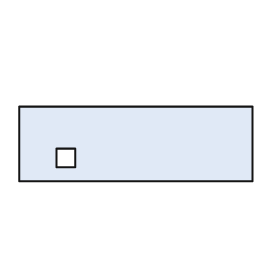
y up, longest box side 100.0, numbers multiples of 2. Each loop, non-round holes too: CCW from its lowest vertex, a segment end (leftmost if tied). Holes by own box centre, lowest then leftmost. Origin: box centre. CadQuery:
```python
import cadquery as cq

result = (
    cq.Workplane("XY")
    .moveTo(-50.0, -16.0)
    .lineTo(50.0, -16.0)
    .lineTo(50.0, 16.0)
    .lineTo(-50.0, 16.0)
    .close()
    .moveTo(-34.0, -10.0)
    .lineTo(-26.0, -10.0)
    .lineTo(-26.0, -2.0)
    .lineTo(-34.0, -2.0)
    .close()
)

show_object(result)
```